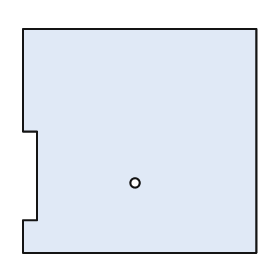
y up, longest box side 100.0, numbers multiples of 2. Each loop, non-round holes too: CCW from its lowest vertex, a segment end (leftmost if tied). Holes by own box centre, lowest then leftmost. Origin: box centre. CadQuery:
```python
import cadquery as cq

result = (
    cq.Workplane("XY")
    .moveTo(-50.0, -48.0)
    .lineTo(50.0, -48.0)
    .lineTo(50.0, 48.0)
    .lineTo(-50.0, 48.0)
    .lineTo(-50.0, 4.0)
    .lineTo(-44.0, 4.0)
    .lineTo(-44.0, -34.0)
    .lineTo(-50.0, -34.0)
    .close()
    .moveTo(-2.0, -18.0)
    .circle(2.0)
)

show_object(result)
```